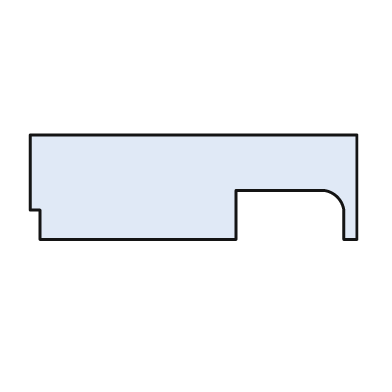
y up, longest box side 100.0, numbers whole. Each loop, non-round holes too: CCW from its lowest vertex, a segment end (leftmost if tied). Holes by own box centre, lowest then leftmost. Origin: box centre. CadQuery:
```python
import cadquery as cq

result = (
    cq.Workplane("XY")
    .moveTo(-47.0, -16.0)
    .lineTo(13.0, -16.0)
    .lineTo(13.0, -1.0)
    .lineTo(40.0, -1.0)
    .threePointArc((44.0, -3.0), (46.0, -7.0))
    .lineTo(46.0, -16.0)
    .lineTo(50.0, -16.0)
    .lineTo(50.0, 16.0)
    .lineTo(-50.0, 16.0)
    .lineTo(-50.0, -7.0)
    .lineTo(-47.0, -7.0)
    .close()
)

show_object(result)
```